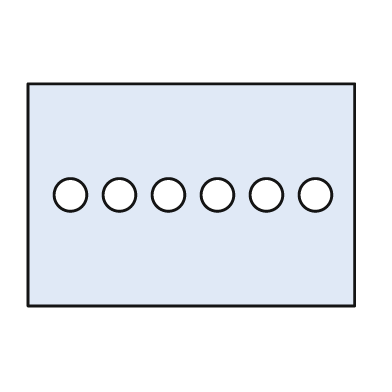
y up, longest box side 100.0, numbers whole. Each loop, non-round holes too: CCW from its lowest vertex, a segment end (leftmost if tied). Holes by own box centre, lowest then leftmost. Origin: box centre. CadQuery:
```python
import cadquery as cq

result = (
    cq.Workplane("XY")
    .moveTo(-50.0, -34.0)
    .lineTo(50.0, -34.0)
    .lineTo(50.0, 34.0)
    .lineTo(-50.0, 34.0)
    .close()
    .moveTo(-37.0, 0.0)
    .circle(5.0)
    .moveTo(-22.0, 0.0)
    .circle(5.0)
    .moveTo(-7.0, 0.0)
    .circle(5.0)
    .moveTo(8.0, 0.0)
    .circle(5.0)
    .moveTo(23.0, 0.0)
    .circle(5.0)
    .moveTo(38.0, 0.0)
    .circle(5.0)
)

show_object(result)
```